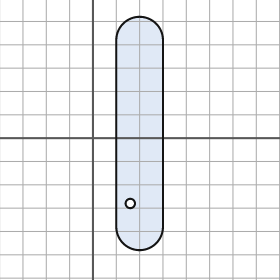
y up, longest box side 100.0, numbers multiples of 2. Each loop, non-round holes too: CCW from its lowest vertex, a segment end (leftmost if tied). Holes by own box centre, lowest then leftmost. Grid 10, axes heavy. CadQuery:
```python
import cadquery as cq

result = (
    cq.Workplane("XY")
    .moveTo(10.0, -38.0)
    .threePointArc((20.0, -48.0), (30.0, -38.0))
    .lineTo(30.0, 42.0)
    .threePointArc((20.0, 52.0), (10.0, 42.0))
    .close()
    .moveTo(16.0, -28.0)
    .circle(2.0)
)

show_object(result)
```